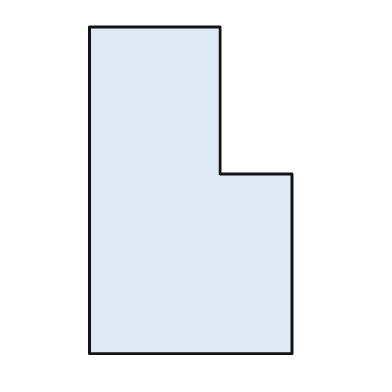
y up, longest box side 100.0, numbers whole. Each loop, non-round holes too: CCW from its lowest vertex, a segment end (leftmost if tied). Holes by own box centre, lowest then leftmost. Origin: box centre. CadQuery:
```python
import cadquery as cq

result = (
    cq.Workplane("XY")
    .moveTo(-31.0, -50.0)
    .lineTo(31.0, -50.0)
    .lineTo(31.0, 5.0)
    .lineTo(9.0, 5.0)
    .lineTo(9.0, 50.0)
    .lineTo(-31.0, 50.0)
    .close()
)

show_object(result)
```